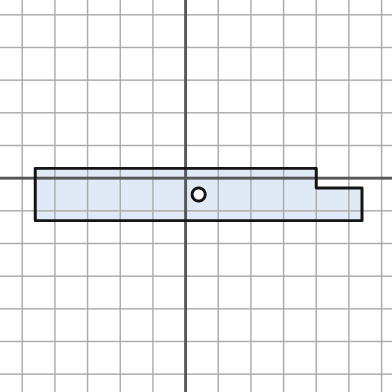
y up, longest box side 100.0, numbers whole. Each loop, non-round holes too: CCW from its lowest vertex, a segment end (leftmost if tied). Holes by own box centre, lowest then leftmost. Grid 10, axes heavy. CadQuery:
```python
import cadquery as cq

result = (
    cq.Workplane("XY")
    .moveTo(-46.0, -13.0)
    .lineTo(54.0, -13.0)
    .lineTo(54.0, -3.0)
    .lineTo(40.0, -3.0)
    .lineTo(40.0, 3.0)
    .lineTo(-46.0, 3.0)
    .close()
    .moveTo(4.0, -5.0)
    .circle(2.0)
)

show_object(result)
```